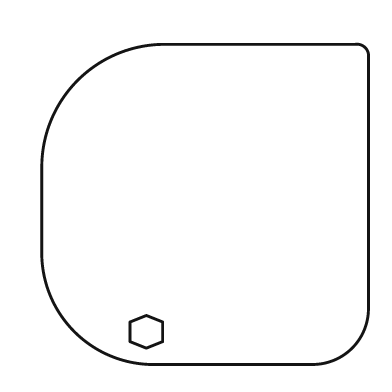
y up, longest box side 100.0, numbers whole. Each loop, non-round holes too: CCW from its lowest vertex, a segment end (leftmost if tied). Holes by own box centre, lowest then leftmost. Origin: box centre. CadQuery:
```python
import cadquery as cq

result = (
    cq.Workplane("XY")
    .moveTo(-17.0, -49.0)
    .lineTo(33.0, -49.0)
    .threePointArc((45.0, -44.0), (50.0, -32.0))
    .lineTo(50.0, 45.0)
    .threePointArc((49.0, 48.0), (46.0, 49.0))
    .lineTo(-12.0, 49.0)
    .threePointArc((-39.0, 38.0), (-50.0, 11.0))
    .lineTo(-50.0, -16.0)
    .threePointArc((-40.0, -39.0), (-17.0, -49.0))
    .close()
    .moveTo(-18.0, -44.0)
    .lineTo(-13.0, -42.0)
    .lineTo(-13.0, -36.0)
    .lineTo(-18.0, -34.0)
    .lineTo(-23.0, -36.0)
    .lineTo(-23.0, -42.0)
    .close()
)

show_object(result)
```